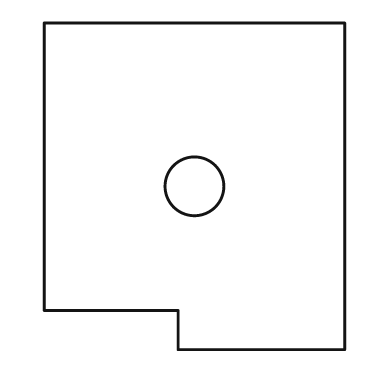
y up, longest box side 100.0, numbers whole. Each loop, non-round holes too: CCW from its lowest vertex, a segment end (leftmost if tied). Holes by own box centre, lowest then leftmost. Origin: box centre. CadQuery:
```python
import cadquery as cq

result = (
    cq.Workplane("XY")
    .moveTo(-5.0, -50.0)
    .lineTo(46.0, -50.0)
    .lineTo(46.0, 50.0)
    .lineTo(-46.0, 50.0)
    .lineTo(-46.0, -38.0)
    .lineTo(-5.0, -38.0)
    .close()
    .moveTo(0.0, 0.0)
    .circle(9.0)
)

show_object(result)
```